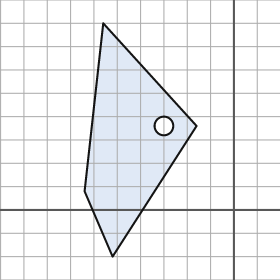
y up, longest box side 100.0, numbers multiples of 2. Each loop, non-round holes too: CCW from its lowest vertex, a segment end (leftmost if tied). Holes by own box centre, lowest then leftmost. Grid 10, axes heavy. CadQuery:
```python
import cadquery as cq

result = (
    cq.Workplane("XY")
    .moveTo(-52.0, -20.0)
    .lineTo(-16.0, 36.0)
    .lineTo(-56.0, 80.0)
    .lineTo(-64.0, 8.0)
    .close()
    .moveTo(-30.0, 36.0)
    .circle(4.0)
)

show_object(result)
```